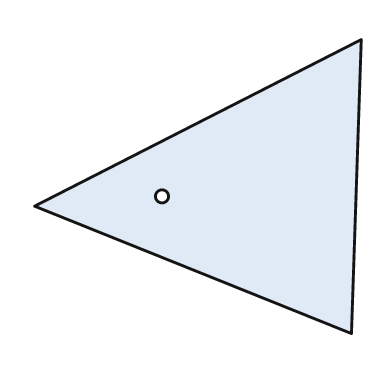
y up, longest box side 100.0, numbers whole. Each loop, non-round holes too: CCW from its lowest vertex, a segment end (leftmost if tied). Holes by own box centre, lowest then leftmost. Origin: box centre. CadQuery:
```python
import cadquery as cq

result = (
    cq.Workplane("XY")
    .moveTo(47.0, -45.0)
    .lineTo(50.0, 45.0)
    .lineTo(-50.0, -6.0)
    .close()
    .moveTo(-11.0, -3.0)
    .circle(2.0)
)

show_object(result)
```